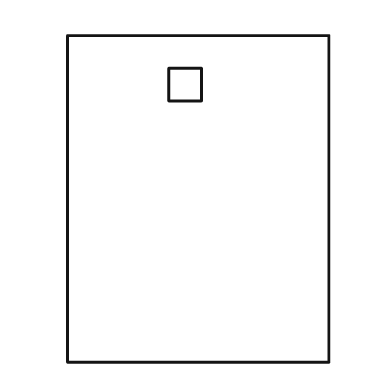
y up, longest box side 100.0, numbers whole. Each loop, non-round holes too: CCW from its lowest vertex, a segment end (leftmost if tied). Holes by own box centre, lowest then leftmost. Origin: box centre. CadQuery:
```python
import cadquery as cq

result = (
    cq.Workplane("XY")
    .moveTo(-40.0, -50.0)
    .lineTo(40.0, -50.0)
    .lineTo(40.0, 50.0)
    .lineTo(-40.0, 50.0)
    .close()
    .moveTo(-9.0, 30.0)
    .lineTo(1.0, 30.0)
    .lineTo(1.0, 40.0)
    .lineTo(-9.0, 40.0)
    .close()
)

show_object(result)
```